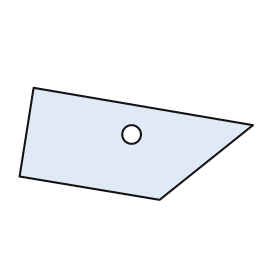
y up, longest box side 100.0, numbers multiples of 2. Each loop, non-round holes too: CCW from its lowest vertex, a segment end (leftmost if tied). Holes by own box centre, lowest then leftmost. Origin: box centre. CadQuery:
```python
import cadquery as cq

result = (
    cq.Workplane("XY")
    .moveTo(10.0, -24.0)
    .lineTo(50.0, 8.0)
    .lineTo(-44.0, 24.0)
    .lineTo(-50.0, -14.0)
    .close()
    .moveTo(-2.0, 4.0)
    .circle(4.0)
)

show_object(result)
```